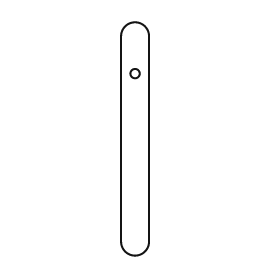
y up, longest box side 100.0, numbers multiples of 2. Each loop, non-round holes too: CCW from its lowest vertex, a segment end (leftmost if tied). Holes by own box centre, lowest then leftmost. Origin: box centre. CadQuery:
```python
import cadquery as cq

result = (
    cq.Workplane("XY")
    .moveTo(-6.0, -44.0)
    .threePointArc((0.0, -50.0), (6.0, -44.0))
    .lineTo(6.0, 44.0)
    .threePointArc((0.0, 50.0), (-6.0, 44.0))
    .close()
    .moveTo(0.0, 28.0)
    .circle(2.0)
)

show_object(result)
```